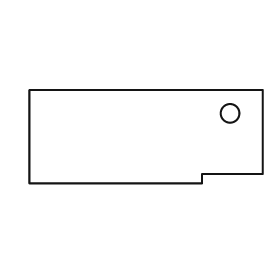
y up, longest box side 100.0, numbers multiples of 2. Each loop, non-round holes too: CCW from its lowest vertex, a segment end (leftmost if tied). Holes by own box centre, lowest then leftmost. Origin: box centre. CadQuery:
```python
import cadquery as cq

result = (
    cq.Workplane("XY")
    .moveTo(-50.0, -20.0)
    .lineTo(24.0, -20.0)
    .lineTo(24.0, -16.0)
    .lineTo(50.0, -16.0)
    .lineTo(50.0, 20.0)
    .lineTo(-50.0, 20.0)
    .close()
    .moveTo(36.0, 10.0)
    .circle(4.0)
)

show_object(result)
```